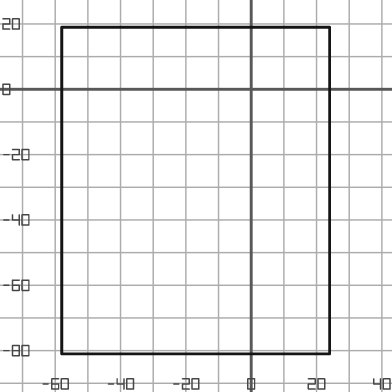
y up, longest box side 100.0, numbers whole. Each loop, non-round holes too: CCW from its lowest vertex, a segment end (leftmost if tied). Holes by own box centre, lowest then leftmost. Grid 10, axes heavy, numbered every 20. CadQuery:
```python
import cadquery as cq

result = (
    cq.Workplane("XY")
    .moveTo(-58.0, -81.0)
    .lineTo(24.0, -81.0)
    .lineTo(24.0, 19.0)
    .lineTo(-58.0, 19.0)
    .close()
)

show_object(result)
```